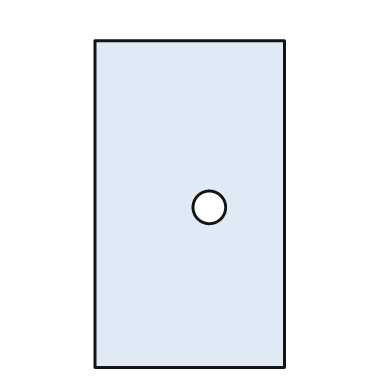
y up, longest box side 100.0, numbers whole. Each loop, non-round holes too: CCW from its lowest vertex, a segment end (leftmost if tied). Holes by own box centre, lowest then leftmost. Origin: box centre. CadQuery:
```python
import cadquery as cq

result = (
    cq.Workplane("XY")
    .moveTo(-29.0, -50.0)
    .lineTo(29.0, -50.0)
    .lineTo(29.0, 50.0)
    .lineTo(-29.0, 50.0)
    .close()
    .moveTo(6.0, -1.0)
    .circle(5.0)
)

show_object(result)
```